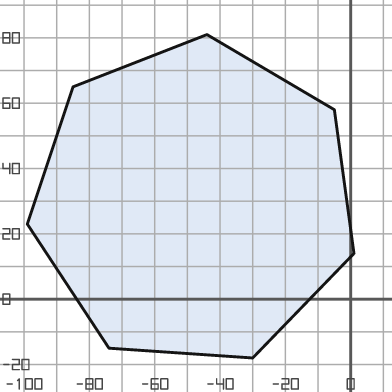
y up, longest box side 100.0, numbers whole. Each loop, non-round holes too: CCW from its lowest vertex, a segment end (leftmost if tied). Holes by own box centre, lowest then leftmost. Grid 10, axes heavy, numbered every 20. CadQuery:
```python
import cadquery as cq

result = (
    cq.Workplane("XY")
    .moveTo(-30.0, -18.0)
    .lineTo(1.0, 14.0)
    .lineTo(-5.0, 58.0)
    .lineTo(-44.0, 81.0)
    .lineTo(-85.0, 65.0)
    .lineTo(-99.0, 23.0)
    .lineTo(-74.0, -15.0)
    .close()
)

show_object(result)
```